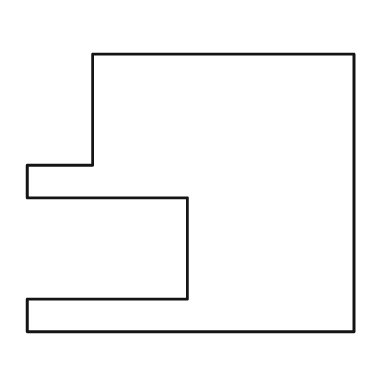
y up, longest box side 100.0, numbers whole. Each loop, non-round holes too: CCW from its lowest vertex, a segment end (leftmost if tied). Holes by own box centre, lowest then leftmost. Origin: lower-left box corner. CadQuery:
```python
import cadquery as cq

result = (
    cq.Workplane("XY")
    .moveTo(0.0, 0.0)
    .lineTo(100.0, 0.0)
    .lineTo(100.0, 85.0)
    .lineTo(20.0, 85.0)
    .lineTo(20.0, 51.0)
    .lineTo(0.0, 51.0)
    .lineTo(0.0, 41.0)
    .lineTo(49.0, 41.0)
    .lineTo(49.0, 10.0)
    .lineTo(0.0, 10.0)
    .close()
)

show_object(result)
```